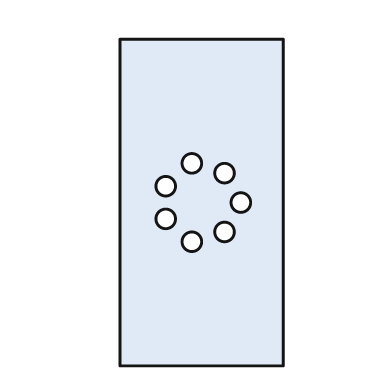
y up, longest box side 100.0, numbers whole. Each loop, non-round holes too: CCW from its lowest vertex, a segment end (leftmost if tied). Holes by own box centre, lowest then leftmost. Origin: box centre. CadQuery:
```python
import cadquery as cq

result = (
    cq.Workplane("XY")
    .moveTo(-25.0, -50.0)
    .lineTo(25.0, -50.0)
    .lineTo(25.0, 50.0)
    .lineTo(-25.0, 50.0)
    .close()
    .moveTo(-3.0, -12.0)
    .circle(3.0)
    .moveTo(7.0, -9.0)
    .circle(3.0)
    .moveTo(-11.0, -5.0)
    .circle(3.0)
    .moveTo(12.0, 0.0)
    .circle(3.0)
    .moveTo(-11.0, 5.0)
    .circle(3.0)
    .moveTo(7.0, 9.0)
    .circle(3.0)
    .moveTo(-3.0, 12.0)
    .circle(3.0)
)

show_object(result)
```